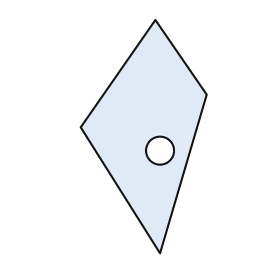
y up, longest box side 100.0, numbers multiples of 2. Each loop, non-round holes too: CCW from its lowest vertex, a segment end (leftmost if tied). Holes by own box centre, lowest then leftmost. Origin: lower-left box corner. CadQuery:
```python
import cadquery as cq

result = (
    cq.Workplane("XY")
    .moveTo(34.0, 0.0)
    .lineTo(54.0, 68.0)
    .lineTo(32.0, 100.0)
    .lineTo(0.0, 54.0)
    .close()
    .moveTo(34.0, 44.0)
    .circle(6.0)
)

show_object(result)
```